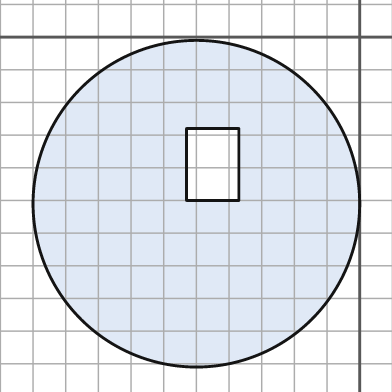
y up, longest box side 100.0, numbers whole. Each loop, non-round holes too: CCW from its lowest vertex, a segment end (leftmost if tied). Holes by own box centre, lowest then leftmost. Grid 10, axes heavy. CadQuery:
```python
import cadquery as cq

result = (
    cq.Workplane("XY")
    .moveTo(-50.0, -51.0)
    .circle(50.0)
    .moveTo(-53.0, -50.0)
    .lineTo(-37.0, -50.0)
    .lineTo(-37.0, -28.0)
    .lineTo(-53.0, -28.0)
    .close()
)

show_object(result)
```